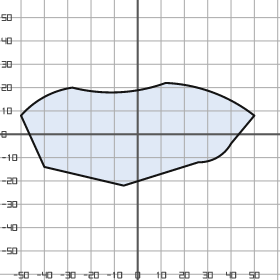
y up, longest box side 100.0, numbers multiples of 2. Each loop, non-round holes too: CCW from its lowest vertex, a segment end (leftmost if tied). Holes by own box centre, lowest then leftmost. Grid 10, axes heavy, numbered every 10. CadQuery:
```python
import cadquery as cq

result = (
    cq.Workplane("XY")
    .moveTo(-6.0, -22.0)
    .lineTo(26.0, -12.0)
    .threePointArc((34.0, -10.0), (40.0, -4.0))
    .lineTo(50.0, 8.0)
    .threePointArc((32.0, 18.0), (12.0, 22.0))
    .threePointArc((-8.0, 18.0), (-28.0, 20.0))
    .threePointArc((-40.0, 16.0), (-50.0, 8.0))
    .lineTo(-40.0, -14.0)
    .close()
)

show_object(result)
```